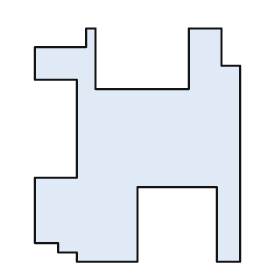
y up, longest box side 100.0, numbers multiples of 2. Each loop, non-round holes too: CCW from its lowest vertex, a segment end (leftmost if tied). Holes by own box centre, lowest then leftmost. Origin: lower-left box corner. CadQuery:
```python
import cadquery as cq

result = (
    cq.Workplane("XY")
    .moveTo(18.0, 0.0)
    .lineTo(44.0, 0.0)
    .lineTo(44.0, 32.0)
    .lineTo(78.0, 32.0)
    .lineTo(78.0, 0.0)
    .lineTo(88.0, 0.0)
    .lineTo(88.0, 84.0)
    .lineTo(80.0, 84.0)
    .lineTo(80.0, 100.0)
    .lineTo(66.0, 100.0)
    .lineTo(66.0, 74.0)
    .lineTo(26.0, 74.0)
    .lineTo(26.0, 100.0)
    .lineTo(22.0, 100.0)
    .lineTo(22.0, 92.0)
    .lineTo(0.0, 92.0)
    .lineTo(0.0, 78.0)
    .lineTo(18.0, 78.0)
    .lineTo(18.0, 36.0)
    .lineTo(0.0, 36.0)
    .lineTo(0.0, 8.0)
    .lineTo(10.0, 8.0)
    .lineTo(10.0, 4.0)
    .lineTo(18.0, 4.0)
    .close()
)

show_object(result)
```